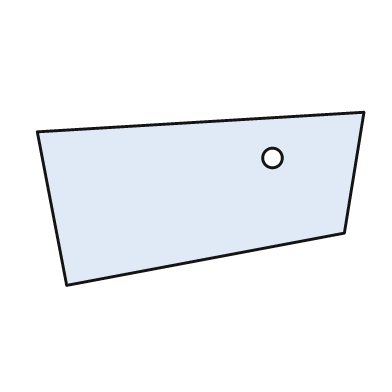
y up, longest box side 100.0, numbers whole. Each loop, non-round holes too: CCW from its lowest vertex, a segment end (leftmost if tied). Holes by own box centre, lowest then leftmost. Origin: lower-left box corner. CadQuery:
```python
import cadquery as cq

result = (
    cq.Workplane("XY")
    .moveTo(9.0, 0.0)
    .lineTo(94.0, 16.0)
    .lineTo(100.0, 53.0)
    .lineTo(0.0, 47.0)
    .close()
    .moveTo(72.0, 39.0)
    .circle(3.0)
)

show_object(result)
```